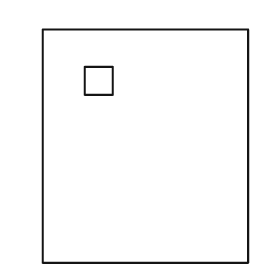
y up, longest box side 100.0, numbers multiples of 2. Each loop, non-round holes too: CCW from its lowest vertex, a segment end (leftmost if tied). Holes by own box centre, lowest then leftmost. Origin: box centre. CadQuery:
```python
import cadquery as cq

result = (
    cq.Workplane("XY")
    .moveTo(-44.0, -50.0)
    .lineTo(44.0, -50.0)
    .lineTo(44.0, 50.0)
    .lineTo(-44.0, 50.0)
    .close()
    .moveTo(-26.0, 22.0)
    .lineTo(-14.0, 22.0)
    .lineTo(-14.0, 34.0)
    .lineTo(-26.0, 34.0)
    .close()
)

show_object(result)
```